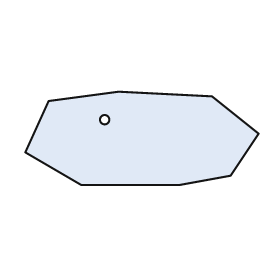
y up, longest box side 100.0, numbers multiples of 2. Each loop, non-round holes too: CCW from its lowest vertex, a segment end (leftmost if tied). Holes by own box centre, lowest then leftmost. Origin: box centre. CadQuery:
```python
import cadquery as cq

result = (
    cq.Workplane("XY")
    .moveTo(-26.0, -20.0)
    .lineTo(16.0, -20.0)
    .lineTo(38.0, -16.0)
    .lineTo(50.0, 2.0)
    .lineTo(30.0, 18.0)
    .lineTo(-10.0, 20.0)
    .lineTo(-40.0, 16.0)
    .lineTo(-50.0, -6.0)
    .close()
    .moveTo(-16.0, 8.0)
    .circle(2.0)
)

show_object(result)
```